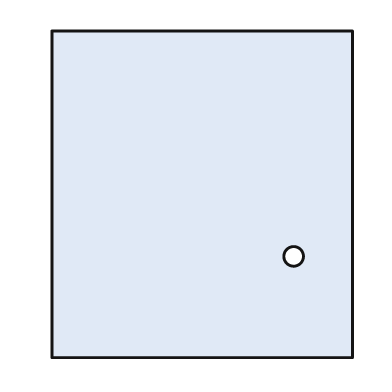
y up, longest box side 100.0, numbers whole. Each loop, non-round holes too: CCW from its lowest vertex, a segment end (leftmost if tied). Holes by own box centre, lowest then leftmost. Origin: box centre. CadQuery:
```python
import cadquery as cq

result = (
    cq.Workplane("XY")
    .moveTo(-46.0, -50.0)
    .lineTo(46.0, -50.0)
    .lineTo(46.0, 50.0)
    .lineTo(-46.0, 50.0)
    .close()
    .moveTo(28.0, -19.0)
    .circle(3.0)
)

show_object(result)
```